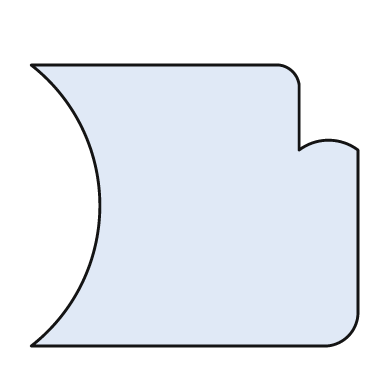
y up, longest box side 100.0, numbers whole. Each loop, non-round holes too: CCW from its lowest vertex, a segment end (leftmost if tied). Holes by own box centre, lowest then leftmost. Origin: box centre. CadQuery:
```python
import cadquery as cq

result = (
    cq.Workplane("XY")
    .moveTo(-50.0, -43.0)
    .lineTo(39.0, -43.0)
    .threePointArc((47.0, -40.0), (50.0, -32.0))
    .lineTo(50.0, 17.0)
    .threePointArc((41.0, 20.0), (32.0, 17.0))
    .lineTo(32.0, 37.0)
    .threePointArc((30.0, 41.0), (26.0, 43.0))
    .lineTo(-50.0, 43.0)
    .threePointArc((-29.0, 0.0), (-50.0, -43.0))
    .close()
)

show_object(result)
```